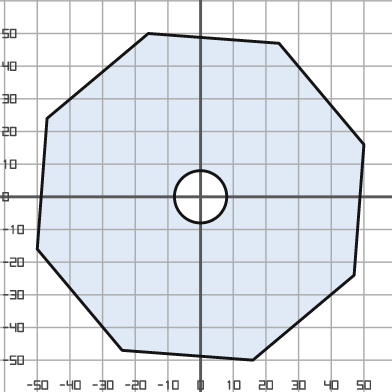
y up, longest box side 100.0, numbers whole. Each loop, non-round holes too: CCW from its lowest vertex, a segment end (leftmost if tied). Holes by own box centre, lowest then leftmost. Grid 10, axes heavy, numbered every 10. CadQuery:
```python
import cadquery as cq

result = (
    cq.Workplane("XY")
    .moveTo(16.0, -50.0)
    .lineTo(47.0, -24.0)
    .lineTo(50.0, 16.0)
    .lineTo(24.0, 47.0)
    .lineTo(-16.0, 50.0)
    .lineTo(-47.0, 24.0)
    .lineTo(-50.0, -16.0)
    .lineTo(-24.0, -47.0)
    .close()
    .moveTo(0.0, 0.0)
    .circle(8.0)
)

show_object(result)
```